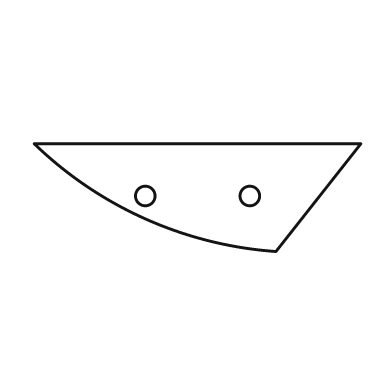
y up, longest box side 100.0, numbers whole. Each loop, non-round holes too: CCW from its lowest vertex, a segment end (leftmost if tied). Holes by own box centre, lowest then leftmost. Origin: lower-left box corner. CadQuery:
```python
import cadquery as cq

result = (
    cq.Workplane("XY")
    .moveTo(74.0, 0.0)
    .lineTo(100.0, 33.0)
    .lineTo(0.0, 33.0)
    .threePointArc((34.0, 10.0), (74.0, 0.0))
    .close()
    .moveTo(34.0, 17.0)
    .circle(3.0)
    .moveTo(66.0, 17.0)
    .circle(3.0)
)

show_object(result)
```